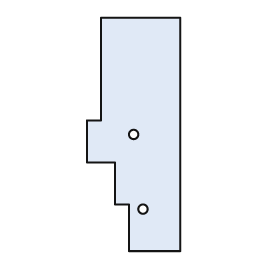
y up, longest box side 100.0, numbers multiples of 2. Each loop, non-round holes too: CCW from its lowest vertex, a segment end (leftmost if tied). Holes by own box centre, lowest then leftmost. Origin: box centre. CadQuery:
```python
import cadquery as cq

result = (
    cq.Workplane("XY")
    .moveTo(-2.0, -50.0)
    .lineTo(20.0, -50.0)
    .lineTo(20.0, 50.0)
    .lineTo(-14.0, 50.0)
    .lineTo(-14.0, 6.0)
    .lineTo(-20.0, 6.0)
    .lineTo(-20.0, -12.0)
    .lineTo(-8.0, -12.0)
    .lineTo(-8.0, -30.0)
    .lineTo(-2.0, -30.0)
    .close()
    .moveTo(4.0, -32.0)
    .circle(2.0)
    .moveTo(0.0, 0.0)
    .circle(2.0)
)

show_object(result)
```